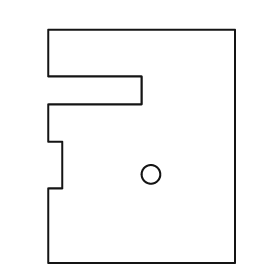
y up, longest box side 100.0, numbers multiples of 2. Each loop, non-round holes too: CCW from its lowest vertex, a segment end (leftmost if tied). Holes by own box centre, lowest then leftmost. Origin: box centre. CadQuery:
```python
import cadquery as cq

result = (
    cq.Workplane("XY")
    .moveTo(-40.0, -50.0)
    .lineTo(40.0, -50.0)
    .lineTo(40.0, 50.0)
    .lineTo(-40.0, 50.0)
    .lineTo(-40.0, 30.0)
    .lineTo(0.0, 30.0)
    .lineTo(0.0, 18.0)
    .lineTo(-40.0, 18.0)
    .lineTo(-40.0, 2.0)
    .lineTo(-34.0, 2.0)
    .lineTo(-34.0, -18.0)
    .lineTo(-40.0, -18.0)
    .close()
    .moveTo(4.0, -12.0)
    .circle(4.0)
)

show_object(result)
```